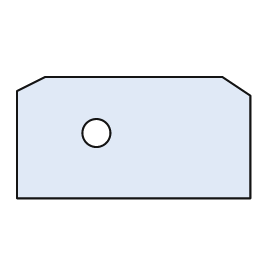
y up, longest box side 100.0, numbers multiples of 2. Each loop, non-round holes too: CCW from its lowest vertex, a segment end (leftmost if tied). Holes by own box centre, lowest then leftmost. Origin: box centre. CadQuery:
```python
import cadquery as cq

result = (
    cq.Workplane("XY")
    .moveTo(-50.0, -26.0)
    .lineTo(50.0, -26.0)
    .lineTo(50.0, 18.0)
    .lineTo(38.0, 26.0)
    .lineTo(-38.0, 26.0)
    .lineTo(-50.0, 20.0)
    .close()
    .moveTo(-16.0, 2.0)
    .circle(6.0)
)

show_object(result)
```